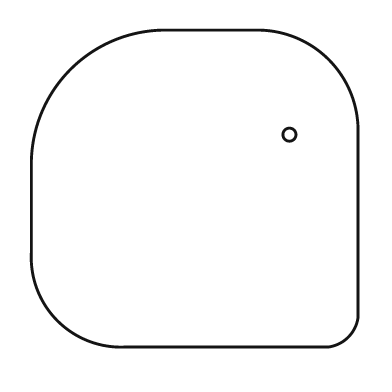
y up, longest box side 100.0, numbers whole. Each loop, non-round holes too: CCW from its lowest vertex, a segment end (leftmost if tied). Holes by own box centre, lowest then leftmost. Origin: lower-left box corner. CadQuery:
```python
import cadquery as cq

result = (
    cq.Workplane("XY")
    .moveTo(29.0, 0.0)
    .lineTo(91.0, 0.0)
    .threePointArc((97.0, 3.0), (100.0, 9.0))
    .lineTo(100.0, 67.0)
    .threePointArc((91.0, 88.0), (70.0, 97.0))
    .lineTo(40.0, 97.0)
    .threePointArc((12.0, 85.0), (0.0, 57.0))
    .lineTo(0.0, 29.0)
    .threePointArc((8.0, 8.0), (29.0, 0.0))
    .close()
    .moveTo(79.0, 65.0)
    .circle(2.0)
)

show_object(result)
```